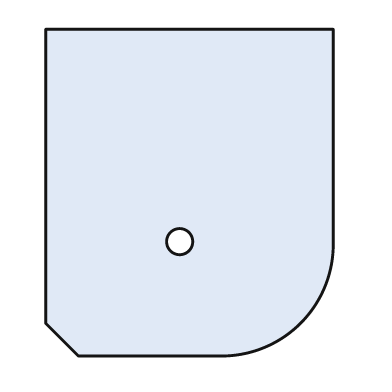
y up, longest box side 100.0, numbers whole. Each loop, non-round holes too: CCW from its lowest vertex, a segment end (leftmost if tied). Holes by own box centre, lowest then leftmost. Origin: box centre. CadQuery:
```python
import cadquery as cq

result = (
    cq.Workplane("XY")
    .moveTo(-34.0, -50.0)
    .lineTo(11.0, -50.0)
    .threePointArc((34.0, -40.0), (44.0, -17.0))
    .lineTo(44.0, 50.0)
    .lineTo(-44.0, 50.0)
    .lineTo(-44.0, -40.0)
    .close()
    .moveTo(-3.0, -15.0)
    .circle(4.0)
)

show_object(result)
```